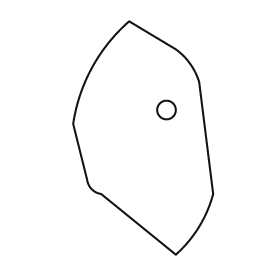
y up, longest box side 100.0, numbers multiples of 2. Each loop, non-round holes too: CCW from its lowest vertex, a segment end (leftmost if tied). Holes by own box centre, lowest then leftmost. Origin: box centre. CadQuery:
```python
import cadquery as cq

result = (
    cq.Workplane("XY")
    .moveTo(14.0, -50.0)
    .threePointArc((24.0, -38.0), (30.0, -24.0))
    .lineTo(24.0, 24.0)
    .threePointArc((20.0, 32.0), (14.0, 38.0))
    .lineTo(-6.0, 50.0)
    .threePointArc((-22.0, 30.0), (-30.0, 6.0))
    .lineTo(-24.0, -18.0)
    .threePointArc((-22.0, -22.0), (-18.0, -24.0))
    .close()
    .moveTo(10.0, 12.0)
    .circle(4.0)
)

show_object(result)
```